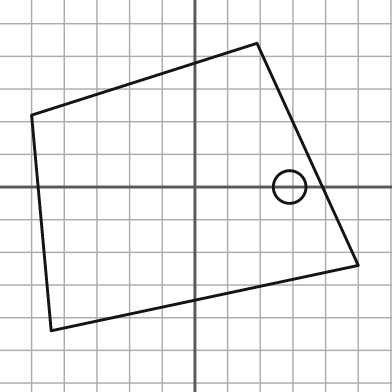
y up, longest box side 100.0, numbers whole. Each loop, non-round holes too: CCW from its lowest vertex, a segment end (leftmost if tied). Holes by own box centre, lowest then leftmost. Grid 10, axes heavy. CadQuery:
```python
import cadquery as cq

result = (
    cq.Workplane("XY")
    .moveTo(-44.0, -44.0)
    .lineTo(50.0, -24.0)
    .lineTo(19.0, 44.0)
    .lineTo(-50.0, 22.0)
    .close()
    .moveTo(29.0, 0.0)
    .circle(5.0)
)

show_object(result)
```